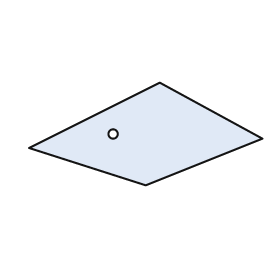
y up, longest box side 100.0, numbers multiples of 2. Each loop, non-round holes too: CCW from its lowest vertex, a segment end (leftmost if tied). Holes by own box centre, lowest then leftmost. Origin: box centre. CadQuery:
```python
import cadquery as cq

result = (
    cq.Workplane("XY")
    .moveTo(0.0, -22.0)
    .lineTo(50.0, -2.0)
    .lineTo(6.0, 22.0)
    .lineTo(-50.0, -6.0)
    .close()
    .moveTo(-14.0, 0.0)
    .circle(2.0)
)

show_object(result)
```